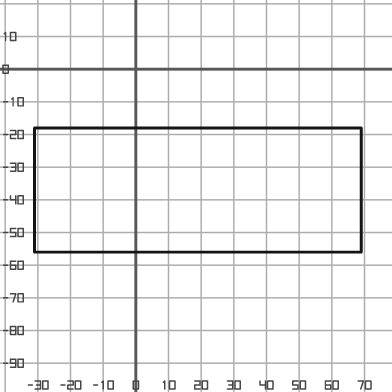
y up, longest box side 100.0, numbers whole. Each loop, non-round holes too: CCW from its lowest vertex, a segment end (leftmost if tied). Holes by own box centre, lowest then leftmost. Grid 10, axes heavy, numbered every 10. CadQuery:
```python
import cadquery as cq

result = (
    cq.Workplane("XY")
    .moveTo(-31.0, -56.0)
    .lineTo(69.0, -56.0)
    .lineTo(69.0, -18.0)
    .lineTo(-31.0, -18.0)
    .close()
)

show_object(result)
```